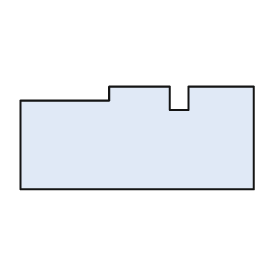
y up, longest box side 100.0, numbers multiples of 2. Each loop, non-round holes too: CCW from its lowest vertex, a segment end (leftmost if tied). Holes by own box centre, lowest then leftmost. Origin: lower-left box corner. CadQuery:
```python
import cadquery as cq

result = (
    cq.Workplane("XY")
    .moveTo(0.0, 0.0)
    .lineTo(100.0, 0.0)
    .lineTo(100.0, 44.0)
    .lineTo(72.0, 44.0)
    .lineTo(72.0, 34.0)
    .lineTo(64.0, 34.0)
    .lineTo(64.0, 44.0)
    .lineTo(38.0, 44.0)
    .lineTo(38.0, 38.0)
    .lineTo(0.0, 38.0)
    .close()
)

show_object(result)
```